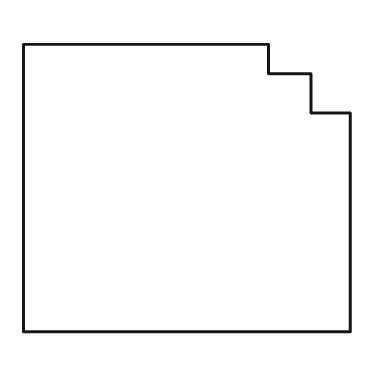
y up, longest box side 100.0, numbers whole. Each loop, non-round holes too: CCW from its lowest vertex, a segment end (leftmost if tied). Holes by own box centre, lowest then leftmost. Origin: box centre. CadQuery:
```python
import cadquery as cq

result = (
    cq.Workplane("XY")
    .moveTo(-50.0, -44.0)
    .lineTo(50.0, -44.0)
    .lineTo(50.0, 23.0)
    .lineTo(38.0, 23.0)
    .lineTo(38.0, 35.0)
    .lineTo(25.0, 35.0)
    .lineTo(25.0, 44.0)
    .lineTo(-50.0, 44.0)
    .close()
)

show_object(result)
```